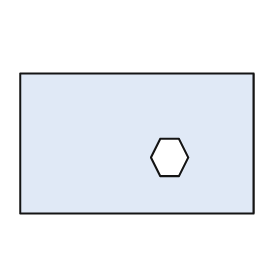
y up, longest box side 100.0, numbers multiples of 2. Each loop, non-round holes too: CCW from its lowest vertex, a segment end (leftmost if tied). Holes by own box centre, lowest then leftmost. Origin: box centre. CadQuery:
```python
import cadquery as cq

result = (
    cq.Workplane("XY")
    .moveTo(-50.0, -30.0)
    .lineTo(50.0, -30.0)
    .lineTo(50.0, 30.0)
    .lineTo(-50.0, 30.0)
    .close()
    .moveTo(10.0, -14.0)
    .lineTo(18.0, -14.0)
    .lineTo(22.0, -6.0)
    .lineTo(18.0, 2.0)
    .lineTo(10.0, 2.0)
    .lineTo(6.0, -6.0)
    .close()
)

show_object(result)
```